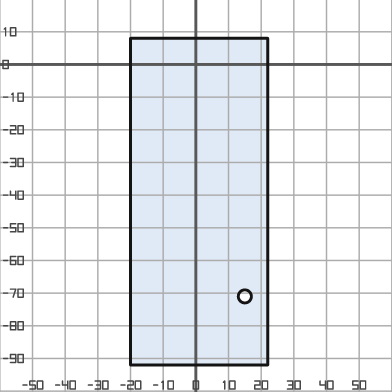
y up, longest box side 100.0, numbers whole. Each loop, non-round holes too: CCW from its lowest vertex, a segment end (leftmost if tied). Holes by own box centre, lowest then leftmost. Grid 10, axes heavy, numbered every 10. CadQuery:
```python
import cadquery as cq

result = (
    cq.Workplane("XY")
    .moveTo(-20.0, -92.0)
    .lineTo(22.0, -92.0)
    .lineTo(22.0, 8.0)
    .lineTo(-20.0, 8.0)
    .close()
    .moveTo(15.0, -71.0)
    .circle(2.0)
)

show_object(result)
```